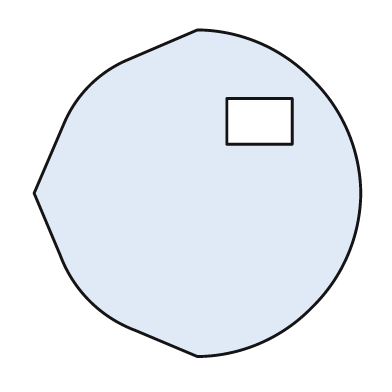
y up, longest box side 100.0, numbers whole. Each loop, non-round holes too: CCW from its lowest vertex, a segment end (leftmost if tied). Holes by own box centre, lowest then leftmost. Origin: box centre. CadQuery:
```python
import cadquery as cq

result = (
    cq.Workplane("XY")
    .moveTo(0.0, -50.0)
    .threePointArc((19.0, -46.0), (35.0, -35.0))
    .threePointArc((46.0, -19.0), (50.0, 0.0))
    .threePointArc((46.0, 19.0), (35.0, 35.0))
    .threePointArc((19.0, 46.0), (0.0, 50.0))
    .lineTo(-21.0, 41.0)
    .threePointArc((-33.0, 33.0), (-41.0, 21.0))
    .lineTo(-50.0, 0.0)
    .lineTo(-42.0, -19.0)
    .threePointArc((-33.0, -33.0), (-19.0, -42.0))
    .close()
    .moveTo(9.0, 15.0)
    .lineTo(29.0, 15.0)
    .lineTo(29.0, 29.0)
    .lineTo(9.0, 29.0)
    .close()
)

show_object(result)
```